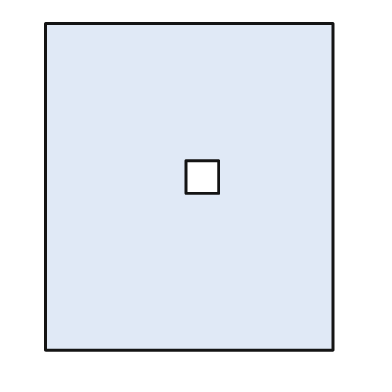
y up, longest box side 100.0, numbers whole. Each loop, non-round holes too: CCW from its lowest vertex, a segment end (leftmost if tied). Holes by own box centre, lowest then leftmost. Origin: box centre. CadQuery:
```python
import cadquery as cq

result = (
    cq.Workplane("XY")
    .moveTo(-44.0, -50.0)
    .lineTo(44.0, -50.0)
    .lineTo(44.0, 50.0)
    .lineTo(-44.0, 50.0)
    .close()
    .moveTo(-1.0, -2.0)
    .lineTo(9.0, -2.0)
    .lineTo(9.0, 8.0)
    .lineTo(-1.0, 8.0)
    .close()
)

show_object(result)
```